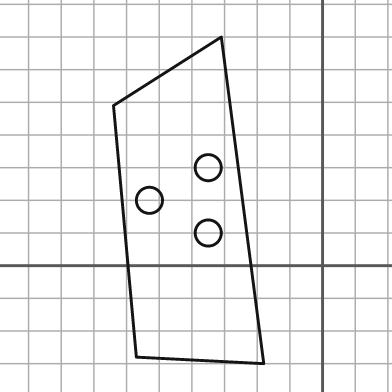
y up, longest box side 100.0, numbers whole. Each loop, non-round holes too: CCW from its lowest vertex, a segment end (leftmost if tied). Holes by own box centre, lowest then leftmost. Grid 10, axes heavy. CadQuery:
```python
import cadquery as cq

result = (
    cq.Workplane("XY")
    .moveTo(-18.0, -30.0)
    .lineTo(-31.0, 70.0)
    .lineTo(-64.0, 49.0)
    .lineTo(-57.0, -28.0)
    .close()
    .moveTo(-35.0, 10.0)
    .circle(4.0)
    .moveTo(-53.0, 20.0)
    .circle(4.0)
    .moveTo(-35.0, 30.0)
    .circle(4.0)
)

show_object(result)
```